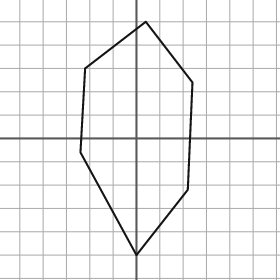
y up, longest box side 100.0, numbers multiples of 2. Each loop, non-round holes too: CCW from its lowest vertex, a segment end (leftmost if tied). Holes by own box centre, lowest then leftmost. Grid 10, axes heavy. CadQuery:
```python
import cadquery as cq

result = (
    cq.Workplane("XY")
    .moveTo(0.0, -50.0)
    .lineTo(22.0, -22.0)
    .lineTo(24.0, 24.0)
    .lineTo(4.0, 50.0)
    .lineTo(-22.0, 30.0)
    .lineTo(-24.0, -6.0)
    .close()
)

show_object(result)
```